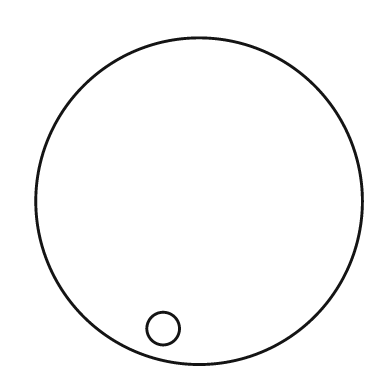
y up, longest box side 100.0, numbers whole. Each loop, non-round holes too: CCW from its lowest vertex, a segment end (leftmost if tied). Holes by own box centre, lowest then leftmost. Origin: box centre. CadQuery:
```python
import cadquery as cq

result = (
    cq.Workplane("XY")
    .moveTo(0.0, 0.0)
    .circle(50.0)
    .moveTo(-11.0, -39.0)
    .circle(5.0)
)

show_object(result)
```